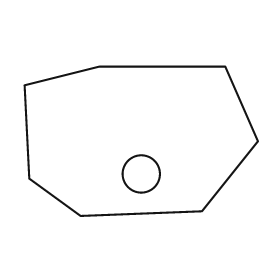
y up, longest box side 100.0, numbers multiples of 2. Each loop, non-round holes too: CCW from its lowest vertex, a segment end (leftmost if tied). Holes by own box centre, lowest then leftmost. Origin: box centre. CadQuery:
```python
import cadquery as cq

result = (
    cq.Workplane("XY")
    .moveTo(-26.0, -32.0)
    .lineTo(26.0, -30.0)
    .lineTo(50.0, 0.0)
    .lineTo(36.0, 32.0)
    .lineTo(-18.0, 32.0)
    .lineTo(-50.0, 24.0)
    .lineTo(-48.0, -16.0)
    .close()
    .moveTo(0.0, -14.0)
    .circle(8.0)
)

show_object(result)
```